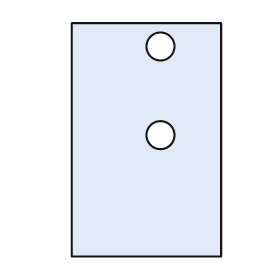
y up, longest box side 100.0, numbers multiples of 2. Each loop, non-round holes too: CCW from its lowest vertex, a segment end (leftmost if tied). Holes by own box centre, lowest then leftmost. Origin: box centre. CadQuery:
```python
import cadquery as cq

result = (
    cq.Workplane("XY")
    .moveTo(-32.0, -50.0)
    .lineTo(32.0, -50.0)
    .lineTo(32.0, 50.0)
    .lineTo(-32.0, 50.0)
    .close()
    .moveTo(6.0, 2.0)
    .circle(6.0)
    .moveTo(6.0, 40.0)
    .circle(6.0)
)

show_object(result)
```